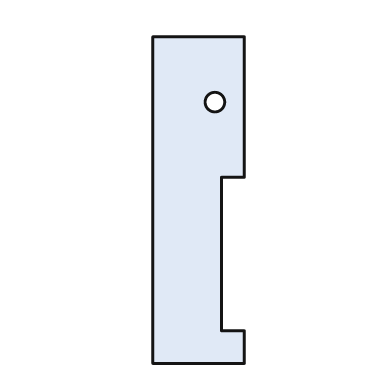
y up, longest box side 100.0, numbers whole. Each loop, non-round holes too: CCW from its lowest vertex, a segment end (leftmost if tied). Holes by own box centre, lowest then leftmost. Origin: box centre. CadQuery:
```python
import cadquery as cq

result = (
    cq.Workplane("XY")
    .moveTo(-14.0, -50.0)
    .lineTo(14.0, -50.0)
    .lineTo(14.0, -40.0)
    .lineTo(7.0, -40.0)
    .lineTo(7.0, 7.0)
    .lineTo(14.0, 7.0)
    .lineTo(14.0, 50.0)
    .lineTo(-14.0, 50.0)
    .close()
    .moveTo(5.0, 30.0)
    .circle(3.0)
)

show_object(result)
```